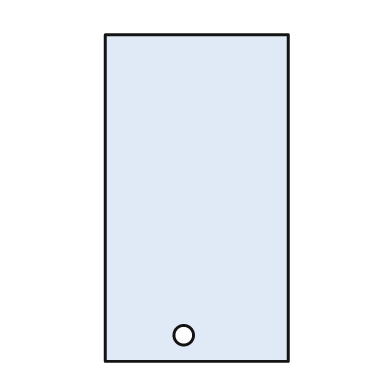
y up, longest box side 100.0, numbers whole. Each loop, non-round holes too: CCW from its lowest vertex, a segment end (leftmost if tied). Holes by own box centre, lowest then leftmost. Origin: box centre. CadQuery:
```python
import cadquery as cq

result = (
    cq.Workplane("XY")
    .moveTo(-28.0, -50.0)
    .lineTo(28.0, -50.0)
    .lineTo(28.0, 50.0)
    .lineTo(-28.0, 50.0)
    .close()
    .moveTo(-4.0, -42.0)
    .circle(3.0)
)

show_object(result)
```